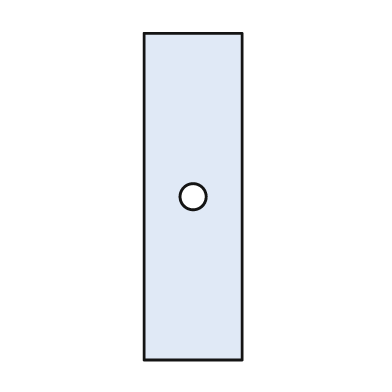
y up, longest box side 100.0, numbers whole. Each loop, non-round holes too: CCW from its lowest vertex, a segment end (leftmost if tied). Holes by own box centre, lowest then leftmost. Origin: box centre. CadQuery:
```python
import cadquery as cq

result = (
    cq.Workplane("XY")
    .moveTo(-15.0, -50.0)
    .lineTo(15.0, -50.0)
    .lineTo(15.0, 50.0)
    .lineTo(-15.0, 50.0)
    .close()
    .moveTo(0.0, 0.0)
    .circle(4.0)
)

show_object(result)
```